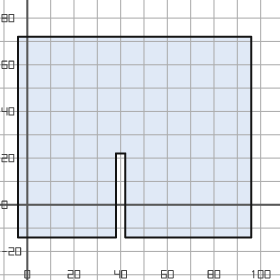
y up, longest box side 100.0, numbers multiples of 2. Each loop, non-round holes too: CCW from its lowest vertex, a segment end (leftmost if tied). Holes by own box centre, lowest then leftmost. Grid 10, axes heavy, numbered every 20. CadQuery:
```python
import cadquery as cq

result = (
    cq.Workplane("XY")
    .moveTo(-4.0, -14.0)
    .lineTo(38.0, -14.0)
    .lineTo(38.0, 22.0)
    .lineTo(42.0, 22.0)
    .lineTo(42.0, -14.0)
    .lineTo(96.0, -14.0)
    .lineTo(96.0, 72.0)
    .lineTo(-4.0, 72.0)
    .close()
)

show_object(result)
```